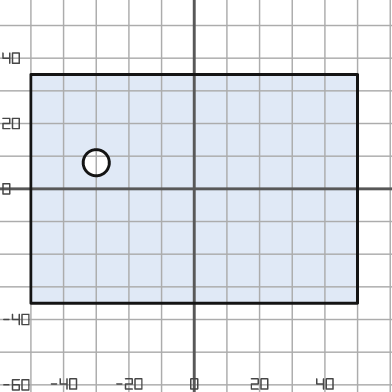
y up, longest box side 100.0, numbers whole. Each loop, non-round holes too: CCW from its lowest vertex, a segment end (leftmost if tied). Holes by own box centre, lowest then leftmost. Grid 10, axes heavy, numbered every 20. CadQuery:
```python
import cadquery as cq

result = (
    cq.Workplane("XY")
    .moveTo(-50.0, -35.0)
    .lineTo(50.0, -35.0)
    .lineTo(50.0, 35.0)
    .lineTo(-50.0, 35.0)
    .close()
    .moveTo(-30.0, 8.0)
    .circle(4.0)
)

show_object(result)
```